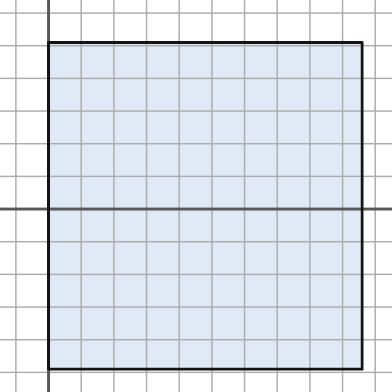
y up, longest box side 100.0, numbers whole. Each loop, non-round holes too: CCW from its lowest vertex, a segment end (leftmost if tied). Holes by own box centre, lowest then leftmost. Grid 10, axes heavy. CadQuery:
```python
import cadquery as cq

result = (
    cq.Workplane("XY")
    .moveTo(0.0, -49.0)
    .lineTo(96.0, -49.0)
    .lineTo(96.0, 51.0)
    .lineTo(0.0, 51.0)
    .close()
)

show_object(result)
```